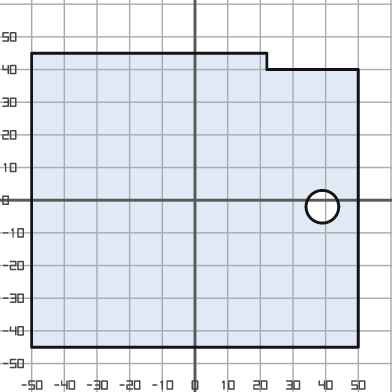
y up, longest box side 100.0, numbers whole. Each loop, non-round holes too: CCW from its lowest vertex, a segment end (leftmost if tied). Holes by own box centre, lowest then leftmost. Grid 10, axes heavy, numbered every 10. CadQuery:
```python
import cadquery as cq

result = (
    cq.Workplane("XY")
    .moveTo(-50.0, -45.0)
    .lineTo(50.0, -45.0)
    .lineTo(50.0, 40.0)
    .lineTo(22.0, 40.0)
    .lineTo(22.0, 45.0)
    .lineTo(-50.0, 45.0)
    .close()
    .moveTo(39.0, -2.0)
    .circle(5.0)
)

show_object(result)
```